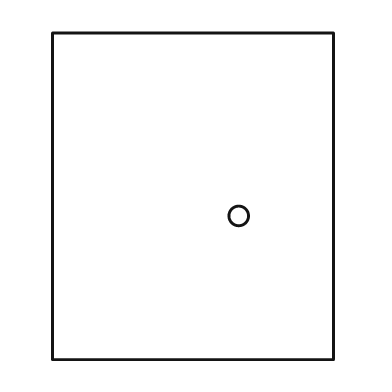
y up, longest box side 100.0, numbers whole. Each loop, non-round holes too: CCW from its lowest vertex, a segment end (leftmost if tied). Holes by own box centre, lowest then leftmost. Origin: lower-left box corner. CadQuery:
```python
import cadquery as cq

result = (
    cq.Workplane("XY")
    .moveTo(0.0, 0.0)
    .lineTo(86.0, 0.0)
    .lineTo(86.0, 100.0)
    .lineTo(0.0, 100.0)
    .close()
    .moveTo(57.0, 44.0)
    .circle(3.0)
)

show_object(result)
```